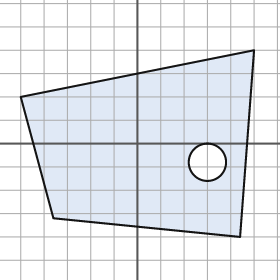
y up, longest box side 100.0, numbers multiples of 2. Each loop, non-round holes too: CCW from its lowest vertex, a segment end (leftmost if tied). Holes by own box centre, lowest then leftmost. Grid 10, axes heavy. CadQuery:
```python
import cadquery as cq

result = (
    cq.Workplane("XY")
    .moveTo(44.0, -40.0)
    .lineTo(50.0, 40.0)
    .lineTo(-50.0, 20.0)
    .lineTo(-36.0, -32.0)
    .close()
    .moveTo(30.0, -8.0)
    .circle(8.0)
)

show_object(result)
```